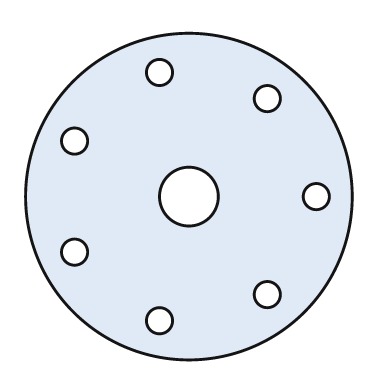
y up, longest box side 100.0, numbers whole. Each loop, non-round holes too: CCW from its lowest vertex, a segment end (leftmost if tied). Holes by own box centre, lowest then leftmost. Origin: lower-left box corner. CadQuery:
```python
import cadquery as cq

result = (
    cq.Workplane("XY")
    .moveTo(50.0, 50.0)
    .circle(50.0)
    .moveTo(41.0, 12.0)
    .circle(4.0)
    .moveTo(74.0, 20.0)
    .circle(4.0)
    .moveTo(15.0, 33.0)
    .circle(4.0)
    .moveTo(50.0, 50.0)
    .circle(9.0)
    .moveTo(89.0, 50.0)
    .circle(4.0)
    .moveTo(15.0, 67.0)
    .circle(4.0)
    .moveTo(74.0, 80.0)
    .circle(4.0)
    .moveTo(41.0, 88.0)
    .circle(4.0)
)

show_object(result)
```